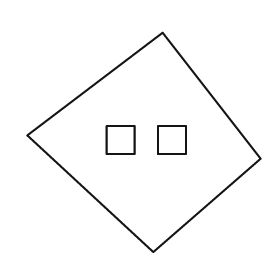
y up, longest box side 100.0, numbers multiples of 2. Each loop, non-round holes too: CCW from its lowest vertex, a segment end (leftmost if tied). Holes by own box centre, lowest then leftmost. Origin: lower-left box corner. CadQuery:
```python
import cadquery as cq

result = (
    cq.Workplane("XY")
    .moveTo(54.0, 0.0)
    .lineTo(100.0, 40.0)
    .lineTo(58.0, 94.0)
    .lineTo(0.0, 50.0)
    .close()
    .moveTo(34.0, 42.0)
    .lineTo(46.0, 42.0)
    .lineTo(46.0, 54.0)
    .lineTo(34.0, 54.0)
    .close()
    .moveTo(56.0, 42.0)
    .lineTo(68.0, 42.0)
    .lineTo(68.0, 54.0)
    .lineTo(56.0, 54.0)
    .close()
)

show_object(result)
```